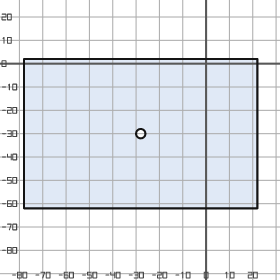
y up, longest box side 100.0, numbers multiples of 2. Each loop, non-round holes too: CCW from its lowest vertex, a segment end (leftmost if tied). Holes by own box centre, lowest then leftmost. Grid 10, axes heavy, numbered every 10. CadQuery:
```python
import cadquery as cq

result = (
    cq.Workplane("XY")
    .moveTo(-78.0, -62.0)
    .lineTo(22.0, -62.0)
    .lineTo(22.0, 2.0)
    .lineTo(-78.0, 2.0)
    .close()
    .moveTo(-28.0, -30.0)
    .circle(2.0)
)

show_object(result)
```